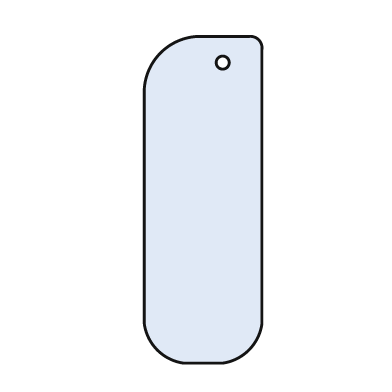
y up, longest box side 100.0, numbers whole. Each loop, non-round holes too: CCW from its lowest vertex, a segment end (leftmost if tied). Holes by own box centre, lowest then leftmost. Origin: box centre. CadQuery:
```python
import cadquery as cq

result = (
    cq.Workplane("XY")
    .moveTo(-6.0, -50.0)
    .lineTo(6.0, -50.0)
    .threePointArc((14.0, -46.0), (18.0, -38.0))
    .lineTo(18.0, 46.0)
    .threePointArc((17.0, 49.0), (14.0, 50.0))
    .lineTo(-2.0, 50.0)
    .threePointArc((-13.0, 45.0), (-18.0, 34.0))
    .lineTo(-18.0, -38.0)
    .threePointArc((-14.0, -46.0), (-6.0, -50.0))
    .close()
    .moveTo(6.0, 42.0)
    .circle(2.0)
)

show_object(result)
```